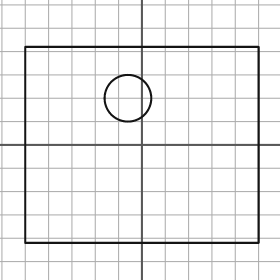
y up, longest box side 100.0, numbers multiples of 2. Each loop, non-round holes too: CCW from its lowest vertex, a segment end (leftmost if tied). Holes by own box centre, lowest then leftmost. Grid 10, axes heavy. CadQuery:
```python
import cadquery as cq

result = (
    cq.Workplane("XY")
    .moveTo(-50.0, -42.0)
    .lineTo(50.0, -42.0)
    .lineTo(50.0, 42.0)
    .lineTo(-50.0, 42.0)
    .close()
    .moveTo(-6.0, 20.0)
    .circle(10.0)
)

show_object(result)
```